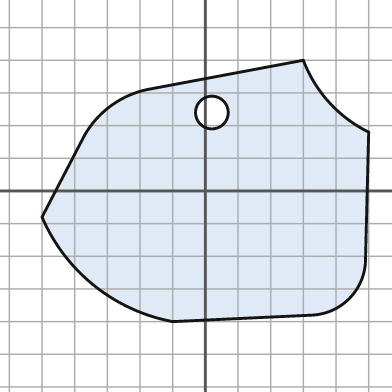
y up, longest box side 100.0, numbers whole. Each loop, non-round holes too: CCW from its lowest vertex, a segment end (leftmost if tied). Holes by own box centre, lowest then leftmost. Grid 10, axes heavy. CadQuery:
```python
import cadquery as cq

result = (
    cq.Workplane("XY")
    .moveTo(-10.0, -40.0)
    .lineTo(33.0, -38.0)
    .threePointArc((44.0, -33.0), (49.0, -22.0))
    .lineTo(50.0, 18.0)
    .threePointArc((38.0, 27.0), (30.0, 40.0))
    .lineTo(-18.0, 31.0)
    .threePointArc((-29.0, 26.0), (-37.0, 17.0))
    .lineTo(-50.0, -8.0)
    .threePointArc((-34.0, -29.0), (-10.0, -40.0))
    .close()
    .moveTo(2.0, 24.0)
    .circle(5.0)
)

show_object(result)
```